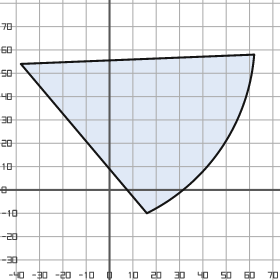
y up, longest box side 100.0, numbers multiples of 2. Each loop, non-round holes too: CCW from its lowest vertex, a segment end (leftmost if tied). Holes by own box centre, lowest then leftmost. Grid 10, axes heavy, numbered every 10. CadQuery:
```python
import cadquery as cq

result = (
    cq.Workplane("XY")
    .moveTo(16.0, -10.0)
    .threePointArc((48.0, 18.0), (62.0, 58.0))
    .lineTo(-38.0, 54.0)
    .close()
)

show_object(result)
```